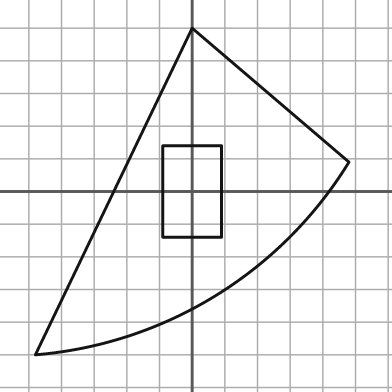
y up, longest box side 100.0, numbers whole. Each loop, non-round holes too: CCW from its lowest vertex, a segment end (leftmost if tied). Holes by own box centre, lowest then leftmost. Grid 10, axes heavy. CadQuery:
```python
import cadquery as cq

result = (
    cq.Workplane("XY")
    .moveTo(-48.0, -50.0)
    .threePointArc((7.0, -32.0), (48.0, 9.0))
    .lineTo(0.0, 50.0)
    .close()
    .moveTo(-9.0, -14.0)
    .lineTo(9.0, -14.0)
    .lineTo(9.0, 14.0)
    .lineTo(-9.0, 14.0)
    .close()
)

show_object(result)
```